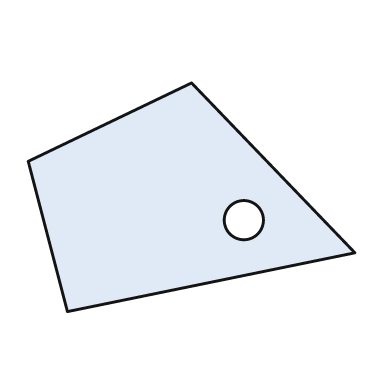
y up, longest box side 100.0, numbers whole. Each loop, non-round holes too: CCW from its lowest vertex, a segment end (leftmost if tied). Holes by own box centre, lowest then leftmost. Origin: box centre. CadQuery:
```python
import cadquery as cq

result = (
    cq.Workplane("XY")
    .moveTo(-38.0, -35.0)
    .lineTo(50.0, -17.0)
    .lineTo(0.0, 35.0)
    .lineTo(-50.0, 11.0)
    .close()
    .moveTo(16.0, -7.0)
    .circle(6.0)
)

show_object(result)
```